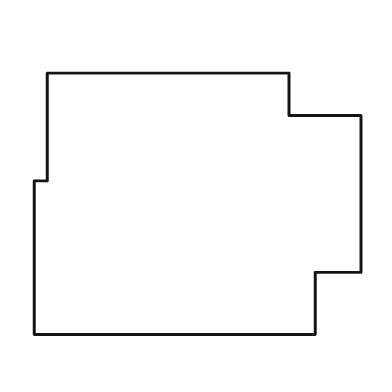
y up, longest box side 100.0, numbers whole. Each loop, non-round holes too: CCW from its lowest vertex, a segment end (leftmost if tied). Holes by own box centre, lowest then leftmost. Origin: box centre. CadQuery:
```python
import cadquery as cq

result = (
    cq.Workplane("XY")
    .moveTo(-50.0, -40.0)
    .lineTo(36.0, -40.0)
    .lineTo(36.0, -21.0)
    .lineTo(50.0, -21.0)
    .lineTo(50.0, 27.0)
    .lineTo(28.0, 27.0)
    .lineTo(28.0, 40.0)
    .lineTo(-46.0, 40.0)
    .lineTo(-46.0, 7.0)
    .lineTo(-50.0, 7.0)
    .close()
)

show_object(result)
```